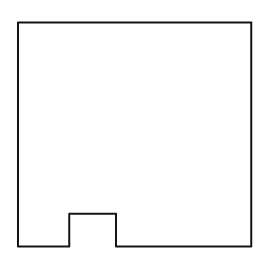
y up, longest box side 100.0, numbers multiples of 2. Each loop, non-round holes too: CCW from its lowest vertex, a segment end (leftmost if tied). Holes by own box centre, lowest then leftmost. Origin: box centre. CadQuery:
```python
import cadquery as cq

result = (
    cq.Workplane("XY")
    .moveTo(-50.0, -48.0)
    .lineTo(-28.0, -48.0)
    .lineTo(-28.0, -34.0)
    .lineTo(-8.0, -34.0)
    .lineTo(-8.0, -48.0)
    .lineTo(50.0, -48.0)
    .lineTo(50.0, 48.0)
    .lineTo(-50.0, 48.0)
    .close()
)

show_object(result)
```